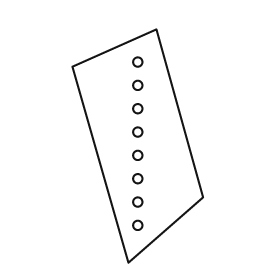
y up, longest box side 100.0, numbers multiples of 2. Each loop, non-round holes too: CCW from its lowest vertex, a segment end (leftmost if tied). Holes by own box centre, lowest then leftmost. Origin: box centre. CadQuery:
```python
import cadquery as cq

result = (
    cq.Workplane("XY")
    .moveTo(-4.0, -50.0)
    .lineTo(28.0, -22.0)
    .lineTo(8.0, 50.0)
    .lineTo(-28.0, 34.0)
    .close()
    .moveTo(0.0, -34.0)
    .circle(2.0)
    .moveTo(0.0, -24.0)
    .circle(2.0)
    .moveTo(0.0, -14.0)
    .circle(2.0)
    .moveTo(0.0, -4.0)
    .circle(2.0)
    .moveTo(0.0, 6.0)
    .circle(2.0)
    .moveTo(0.0, 16.0)
    .circle(2.0)
    .moveTo(0.0, 26.0)
    .circle(2.0)
    .moveTo(0.0, 36.0)
    .circle(2.0)
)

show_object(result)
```